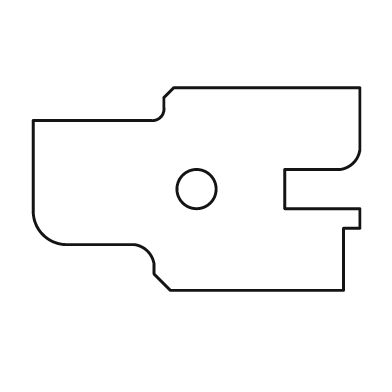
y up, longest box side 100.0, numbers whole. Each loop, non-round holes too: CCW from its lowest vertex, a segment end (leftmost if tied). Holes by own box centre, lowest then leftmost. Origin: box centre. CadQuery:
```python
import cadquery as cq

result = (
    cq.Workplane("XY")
    .moveTo(-8.0, -31.0)
    .lineTo(45.0, -31.0)
    .lineTo(45.0, -12.0)
    .lineTo(50.0, -12.0)
    .lineTo(50.0, -6.0)
    .lineTo(27.0, -6.0)
    .lineTo(27.0, 6.0)
    .lineTo(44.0, 6.0)
    .threePointArc((48.0, 8.0), (50.0, 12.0))
    .lineTo(50.0, 31.0)
    .lineTo(-7.0, 31.0)
    .lineTo(-10.0, 28.0)
    .lineTo(-10.0, 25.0)
    .threePointArc((-11.0, 22.0), (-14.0, 21.0))
    .lineTo(-50.0, 21.0)
    .lineTo(-50.0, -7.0)
    .threePointArc((-47.0, -14.0), (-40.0, -17.0))
    .lineTo(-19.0, -17.0)
    .threePointArc((-15.0, -19.0), (-13.0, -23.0))
    .lineTo(-13.0, -26.0)
    .close()
    .moveTo(0.0, 0.0)
    .circle(6.0)
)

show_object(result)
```